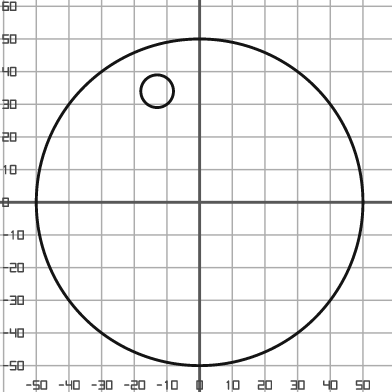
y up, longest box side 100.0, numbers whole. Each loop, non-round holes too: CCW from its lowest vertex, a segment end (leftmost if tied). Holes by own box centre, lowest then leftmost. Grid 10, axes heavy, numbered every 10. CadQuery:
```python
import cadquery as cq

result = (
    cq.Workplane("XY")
    .moveTo(0.0, 0.0)
    .circle(50.0)
    .moveTo(-13.0, 34.0)
    .circle(5.0)
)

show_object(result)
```